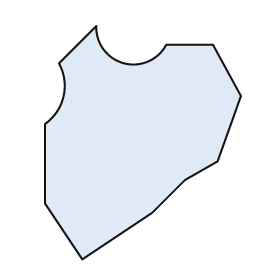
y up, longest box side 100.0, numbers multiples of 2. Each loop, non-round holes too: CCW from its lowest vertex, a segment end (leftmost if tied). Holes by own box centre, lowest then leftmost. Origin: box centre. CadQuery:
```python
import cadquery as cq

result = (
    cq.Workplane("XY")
    .moveTo(-26.0, -50.0)
    .lineTo(4.0, -30.0)
    .lineTo(18.0, -16.0)
    .lineTo(32.0, -8.0)
    .lineTo(42.0, 20.0)
    .lineTo(30.0, 42.0)
    .lineTo(10.0, 42.0)
    .threePointArc((-8.0, 34.0), (-20.0, 50.0))
    .lineTo(-36.0, 34.0)
    .threePointArc((-34.0, 20.0), (-42.0, 8.0))
    .lineTo(-42.0, -26.0)
    .close()
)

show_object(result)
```